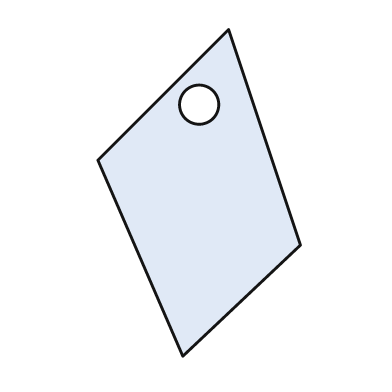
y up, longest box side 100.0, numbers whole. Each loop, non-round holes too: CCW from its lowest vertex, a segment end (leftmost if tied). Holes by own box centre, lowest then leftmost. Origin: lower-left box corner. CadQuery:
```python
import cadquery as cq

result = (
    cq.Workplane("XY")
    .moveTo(26.0, 0.0)
    .lineTo(62.0, 34.0)
    .lineTo(40.0, 100.0)
    .lineTo(0.0, 60.0)
    .close()
    .moveTo(31.0, 77.0)
    .circle(6.0)
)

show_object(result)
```